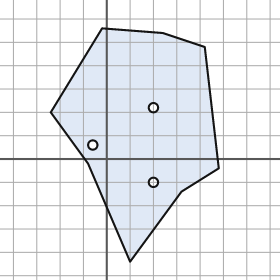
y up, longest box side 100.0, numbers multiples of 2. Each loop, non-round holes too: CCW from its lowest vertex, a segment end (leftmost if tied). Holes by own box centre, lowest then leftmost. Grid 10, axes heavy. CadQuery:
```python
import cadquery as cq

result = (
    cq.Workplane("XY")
    .moveTo(10.0, -44.0)
    .lineTo(32.0, -14.0)
    .lineTo(48.0, -4.0)
    .lineTo(42.0, 48.0)
    .lineTo(24.0, 54.0)
    .lineTo(-2.0, 56.0)
    .lineTo(-24.0, 20.0)
    .lineTo(-8.0, -2.0)
    .close()
    .moveTo(20.0, -10.0)
    .circle(2.0)
    .moveTo(-6.0, 6.0)
    .circle(2.0)
    .moveTo(20.0, 22.0)
    .circle(2.0)
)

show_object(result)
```